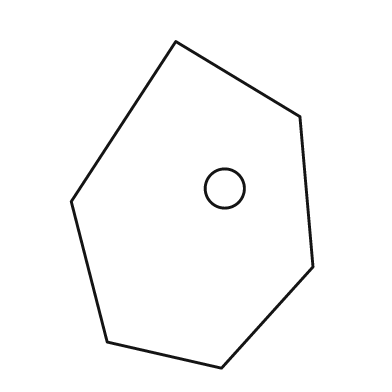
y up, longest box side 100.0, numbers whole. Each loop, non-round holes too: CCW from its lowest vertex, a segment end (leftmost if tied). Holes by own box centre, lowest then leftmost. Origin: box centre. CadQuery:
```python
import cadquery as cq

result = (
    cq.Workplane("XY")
    .moveTo(9.0, -50.0)
    .lineTo(37.0, -19.0)
    .lineTo(33.0, 27.0)
    .lineTo(-5.0, 50.0)
    .lineTo(-37.0, 1.0)
    .lineTo(-26.0, -42.0)
    .close()
    .moveTo(10.0, 5.0)
    .circle(6.0)
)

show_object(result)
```